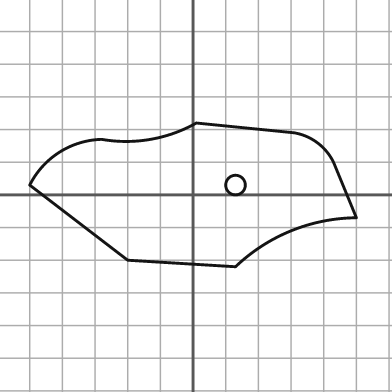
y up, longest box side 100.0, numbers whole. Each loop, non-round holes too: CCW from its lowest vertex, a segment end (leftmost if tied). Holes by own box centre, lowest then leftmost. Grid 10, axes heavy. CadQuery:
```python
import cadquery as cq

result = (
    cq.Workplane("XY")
    .moveTo(13.0, -22.0)
    .threePointArc((30.0, -11.0), (50.0, -7.0))
    .lineTo(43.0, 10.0)
    .threePointArc((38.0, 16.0), (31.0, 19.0))
    .lineTo(1.0, 22.0)
    .threePointArc((-13.0, 17.0), (-28.0, 17.0))
    .threePointArc((-41.0, 13.0), (-50.0, 3.0))
    .lineTo(-20.0, -20.0)
    .close()
    .moveTo(13.0, 3.0)
    .circle(3.0)
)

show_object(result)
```